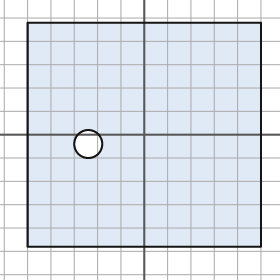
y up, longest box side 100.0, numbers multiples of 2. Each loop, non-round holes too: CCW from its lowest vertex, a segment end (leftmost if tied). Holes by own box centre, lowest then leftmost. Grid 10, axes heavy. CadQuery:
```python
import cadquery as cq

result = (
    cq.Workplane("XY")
    .moveTo(-50.0, -48.0)
    .lineTo(50.0, -48.0)
    .lineTo(50.0, 48.0)
    .lineTo(-50.0, 48.0)
    .close()
    .moveTo(-24.0, -4.0)
    .circle(6.0)
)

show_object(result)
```